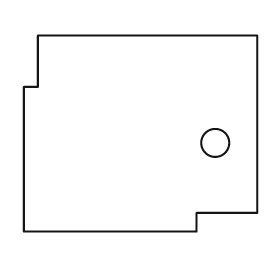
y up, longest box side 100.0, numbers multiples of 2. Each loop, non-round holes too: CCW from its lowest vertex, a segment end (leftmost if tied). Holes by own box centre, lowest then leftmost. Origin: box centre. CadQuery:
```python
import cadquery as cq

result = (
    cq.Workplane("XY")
    .moveTo(-50.0, -42.0)
    .lineTo(24.0, -42.0)
    .lineTo(24.0, -34.0)
    .lineTo(50.0, -34.0)
    .lineTo(50.0, 42.0)
    .lineTo(-44.0, 42.0)
    .lineTo(-44.0, 20.0)
    .lineTo(-50.0, 20.0)
    .close()
    .moveTo(32.0, -4.0)
    .circle(6.0)
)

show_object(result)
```